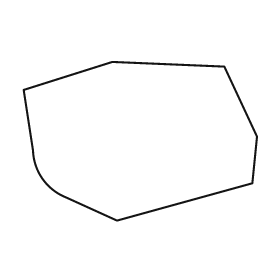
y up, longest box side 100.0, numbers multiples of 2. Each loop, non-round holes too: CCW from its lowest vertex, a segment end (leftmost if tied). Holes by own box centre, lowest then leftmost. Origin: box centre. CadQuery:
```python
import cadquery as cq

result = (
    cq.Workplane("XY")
    .moveTo(-10.0, -34.0)
    .lineTo(48.0, -18.0)
    .lineTo(50.0, 2.0)
    .lineTo(36.0, 32.0)
    .lineTo(-12.0, 34.0)
    .lineTo(-50.0, 22.0)
    .lineTo(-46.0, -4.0)
    .threePointArc((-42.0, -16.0), (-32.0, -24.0))
    .close()
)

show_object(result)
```